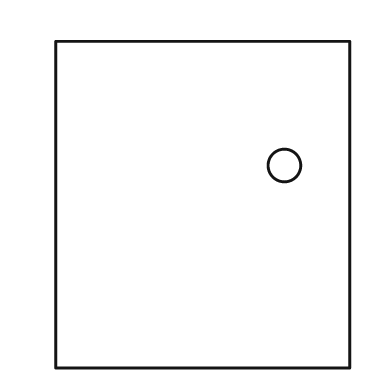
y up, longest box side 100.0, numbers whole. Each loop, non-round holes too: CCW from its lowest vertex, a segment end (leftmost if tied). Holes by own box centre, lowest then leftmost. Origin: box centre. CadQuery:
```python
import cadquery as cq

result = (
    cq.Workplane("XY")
    .moveTo(-45.0, -50.0)
    .lineTo(45.0, -50.0)
    .lineTo(45.0, 50.0)
    .lineTo(-45.0, 50.0)
    .close()
    .moveTo(25.0, 12.0)
    .circle(5.0)
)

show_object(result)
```